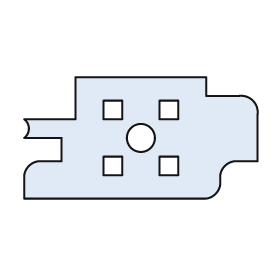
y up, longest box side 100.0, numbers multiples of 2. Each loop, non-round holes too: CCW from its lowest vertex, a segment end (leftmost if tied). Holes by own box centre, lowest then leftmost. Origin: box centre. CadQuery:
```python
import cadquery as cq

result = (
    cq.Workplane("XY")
    .moveTo(-50.0, -26.0)
    .lineTo(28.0, -26.0)
    .threePointArc((32.0, -24.0), (34.0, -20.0))
    .lineTo(34.0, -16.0)
    .threePointArc((36.0, -12.0), (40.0, -10.0))
    .lineTo(50.0, -10.0)
    .lineTo(50.0, 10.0)
    .threePointArc((48.0, 16.0), (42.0, 18.0))
    .lineTo(28.0, 18.0)
    .lineTo(28.0, 26.0)
    .lineTo(-28.0, 26.0)
    .lineTo(-28.0, 8.0)
    .lineTo(-50.0, 8.0)
    .threePointArc((-48.0, 4.0), (-50.0, 0.0))
    .lineTo(-34.0, 0.0)
    .lineTo(-34.0, -10.0)
    .lineTo(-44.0, -10.0)
    .threePointArc((-48.0, -12.0), (-50.0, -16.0))
    .close()
    .moveTo(-16.0, -16.0)
    .lineTo(-8.0, -16.0)
    .lineTo(-8.0, -8.0)
    .lineTo(-16.0, -8.0)
    .close()
    .moveTo(8.0, -16.0)
    .lineTo(16.0, -16.0)
    .lineTo(16.0, -8.0)
    .lineTo(8.0, -8.0)
    .close()
    .moveTo(0.0, 0.0)
    .circle(6.0)
    .moveTo(-16.0, 8.0)
    .lineTo(-8.0, 8.0)
    .lineTo(-8.0, 16.0)
    .lineTo(-16.0, 16.0)
    .close()
    .moveTo(8.0, 8.0)
    .lineTo(16.0, 8.0)
    .lineTo(16.0, 16.0)
    .lineTo(8.0, 16.0)
    .close()
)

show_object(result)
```